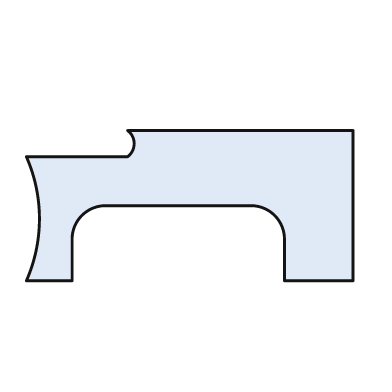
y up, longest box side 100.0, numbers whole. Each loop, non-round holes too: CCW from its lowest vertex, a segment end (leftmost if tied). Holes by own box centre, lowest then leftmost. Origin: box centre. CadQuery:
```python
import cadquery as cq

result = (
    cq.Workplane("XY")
    .moveTo(-50.0, -23.0)
    .lineTo(-36.0, -23.0)
    .lineTo(-36.0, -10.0)
    .threePointArc((-33.0, -3.0), (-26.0, 0.0))
    .lineTo(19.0, 0.0)
    .threePointArc((26.0, -3.0), (29.0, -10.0))
    .lineTo(29.0, -23.0)
    .lineTo(50.0, -23.0)
    .lineTo(50.0, 23.0)
    .lineTo(-19.0, 23.0)
    .threePointArc((-17.0, 19.0), (-19.0, 15.0))
    .lineTo(-50.0, 15.0)
    .threePointArc((-46.0, -4.0), (-50.0, -23.0))
    .close()
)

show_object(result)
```